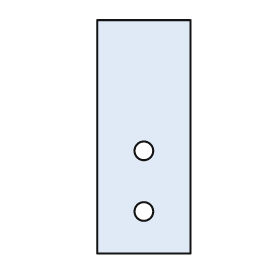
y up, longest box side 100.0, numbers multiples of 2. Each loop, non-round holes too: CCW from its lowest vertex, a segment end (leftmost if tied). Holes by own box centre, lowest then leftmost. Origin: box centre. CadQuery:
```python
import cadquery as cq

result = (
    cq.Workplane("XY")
    .moveTo(-20.0, -50.0)
    .lineTo(20.0, -50.0)
    .lineTo(20.0, 50.0)
    .lineTo(-20.0, 50.0)
    .close()
    .moveTo(0.0, -32.0)
    .circle(4.0)
    .moveTo(0.0, -6.0)
    .circle(4.0)
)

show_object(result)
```